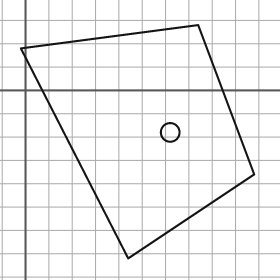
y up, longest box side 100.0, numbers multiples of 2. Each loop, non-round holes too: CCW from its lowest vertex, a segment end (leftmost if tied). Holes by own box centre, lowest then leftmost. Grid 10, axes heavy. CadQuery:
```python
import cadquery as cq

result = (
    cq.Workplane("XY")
    .moveTo(44.0, -72.0)
    .lineTo(98.0, -36.0)
    .lineTo(74.0, 28.0)
    .lineTo(-2.0, 18.0)
    .close()
    .moveTo(62.0, -18.0)
    .circle(4.0)
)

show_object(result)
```